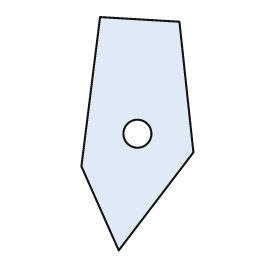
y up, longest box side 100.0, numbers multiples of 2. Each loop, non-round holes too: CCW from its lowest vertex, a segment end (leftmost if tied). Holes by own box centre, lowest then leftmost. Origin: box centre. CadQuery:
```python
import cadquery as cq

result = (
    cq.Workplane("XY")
    .moveTo(-8.0, -50.0)
    .lineTo(24.0, -8.0)
    .lineTo(18.0, 48.0)
    .lineTo(-16.0, 50.0)
    .lineTo(-24.0, -14.0)
    .close()
    .moveTo(0.0, 0.0)
    .circle(6.0)
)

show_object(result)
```